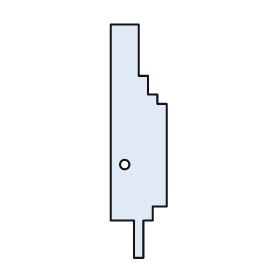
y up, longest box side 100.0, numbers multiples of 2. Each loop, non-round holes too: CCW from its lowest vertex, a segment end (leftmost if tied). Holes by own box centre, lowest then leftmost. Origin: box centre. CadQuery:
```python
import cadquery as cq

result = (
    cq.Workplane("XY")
    .moveTo(-2.0, -50.0)
    .lineTo(2.0, -50.0)
    .lineTo(2.0, -34.0)
    .lineTo(6.0, -34.0)
    .lineTo(6.0, -28.0)
    .lineTo(12.0, -28.0)
    .lineTo(12.0, 16.0)
    .lineTo(8.0, 16.0)
    .lineTo(8.0, 20.0)
    .lineTo(4.0, 20.0)
    .lineTo(4.0, 28.0)
    .lineTo(0.0, 28.0)
    .lineTo(0.0, 50.0)
    .lineTo(-12.0, 50.0)
    .lineTo(-12.0, -34.0)
    .lineTo(-2.0, -34.0)
    .close()
    .moveTo(-6.0, -10.0)
    .circle(2.0)
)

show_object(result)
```